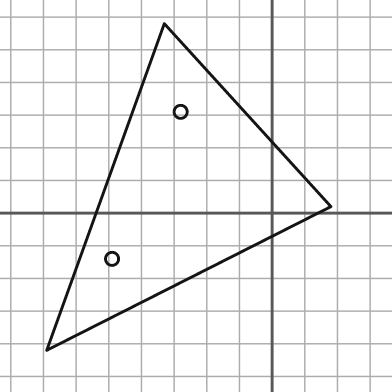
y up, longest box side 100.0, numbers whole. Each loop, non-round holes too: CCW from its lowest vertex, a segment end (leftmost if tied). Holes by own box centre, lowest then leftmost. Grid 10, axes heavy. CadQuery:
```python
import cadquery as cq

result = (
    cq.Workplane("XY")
    .moveTo(-69.0, -42.0)
    .lineTo(18.0, 2.0)
    .lineTo(-33.0, 58.0)
    .close()
    .moveTo(-49.0, -14.0)
    .circle(2.0)
    .moveTo(-28.0, 31.0)
    .circle(2.0)
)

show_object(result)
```